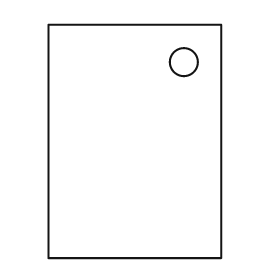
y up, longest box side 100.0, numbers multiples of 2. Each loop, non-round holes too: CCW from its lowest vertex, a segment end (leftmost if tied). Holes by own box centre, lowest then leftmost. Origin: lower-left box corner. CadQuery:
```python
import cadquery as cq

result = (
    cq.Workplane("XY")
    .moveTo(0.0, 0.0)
    .lineTo(74.0, 0.0)
    .lineTo(74.0, 100.0)
    .lineTo(0.0, 100.0)
    .close()
    .moveTo(58.0, 84.0)
    .circle(6.0)
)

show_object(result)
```